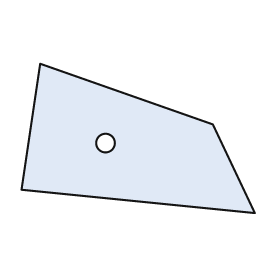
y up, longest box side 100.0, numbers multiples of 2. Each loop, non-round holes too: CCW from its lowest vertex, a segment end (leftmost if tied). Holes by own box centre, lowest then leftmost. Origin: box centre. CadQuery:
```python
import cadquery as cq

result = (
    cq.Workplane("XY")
    .moveTo(50.0, -32.0)
    .lineTo(32.0, 6.0)
    .lineTo(-42.0, 32.0)
    .lineTo(-50.0, -22.0)
    .close()
    .moveTo(-14.0, -2.0)
    .circle(4.0)
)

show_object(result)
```